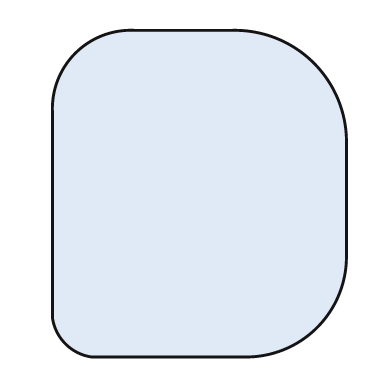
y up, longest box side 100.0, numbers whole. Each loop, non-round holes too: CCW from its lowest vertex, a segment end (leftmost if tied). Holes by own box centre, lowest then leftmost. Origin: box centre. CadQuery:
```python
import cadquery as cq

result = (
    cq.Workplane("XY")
    .moveTo(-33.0, -50.0)
    .lineTo(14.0, -50.0)
    .threePointArc((36.0, -41.0), (45.0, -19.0))
    .lineTo(45.0, 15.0)
    .threePointArc((35.0, 40.0), (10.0, 50.0))
    .lineTo(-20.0, 50.0)
    .threePointArc((-38.0, 43.0), (-45.0, 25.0))
    .lineTo(-45.0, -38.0)
    .threePointArc((-41.0, -46.0), (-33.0, -50.0))
    .close()
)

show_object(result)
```